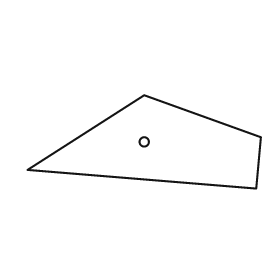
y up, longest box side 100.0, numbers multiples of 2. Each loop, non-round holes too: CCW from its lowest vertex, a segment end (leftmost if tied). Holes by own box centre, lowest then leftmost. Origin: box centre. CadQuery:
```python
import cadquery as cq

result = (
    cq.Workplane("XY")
    .moveTo(48.0, -20.0)
    .lineTo(50.0, 2.0)
    .lineTo(0.0, 20.0)
    .lineTo(-50.0, -12.0)
    .close()
    .moveTo(0.0, 0.0)
    .circle(2.0)
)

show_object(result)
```